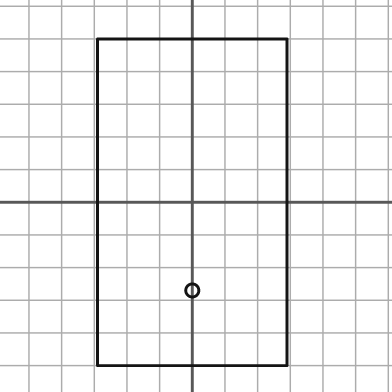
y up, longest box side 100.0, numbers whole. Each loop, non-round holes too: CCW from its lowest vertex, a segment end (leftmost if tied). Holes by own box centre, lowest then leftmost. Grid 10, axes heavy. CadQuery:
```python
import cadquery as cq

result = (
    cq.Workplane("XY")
    .moveTo(-29.0, -50.0)
    .lineTo(29.0, -50.0)
    .lineTo(29.0, 50.0)
    .lineTo(-29.0, 50.0)
    .close()
    .moveTo(0.0, -27.0)
    .circle(2.0)
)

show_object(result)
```